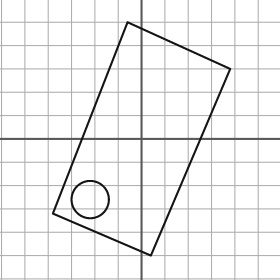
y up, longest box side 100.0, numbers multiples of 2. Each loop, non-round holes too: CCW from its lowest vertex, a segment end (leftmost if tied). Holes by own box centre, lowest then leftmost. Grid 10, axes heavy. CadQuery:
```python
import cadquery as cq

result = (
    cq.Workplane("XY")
    .moveTo(4.0, -50.0)
    .lineTo(38.0, 30.0)
    .lineTo(-6.0, 50.0)
    .lineTo(-38.0, -32.0)
    .close()
    .moveTo(-22.0, -26.0)
    .circle(8.0)
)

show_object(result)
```